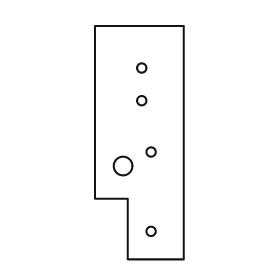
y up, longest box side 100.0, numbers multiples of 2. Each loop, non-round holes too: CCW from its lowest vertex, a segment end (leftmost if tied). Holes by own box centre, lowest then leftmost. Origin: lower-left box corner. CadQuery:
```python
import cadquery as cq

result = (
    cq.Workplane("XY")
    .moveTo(14.0, 0.0)
    .lineTo(38.0, 0.0)
    .lineTo(38.0, 100.0)
    .lineTo(0.0, 100.0)
    .lineTo(0.0, 26.0)
    .lineTo(14.0, 26.0)
    .close()
    .moveTo(24.0, 12.0)
    .circle(2.0)
    .moveTo(12.0, 40.0)
    .circle(4.0)
    .moveTo(24.0, 46.0)
    .circle(2.0)
    .moveTo(20.0, 68.0)
    .circle(2.0)
    .moveTo(20.0, 82.0)
    .circle(2.0)
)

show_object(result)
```